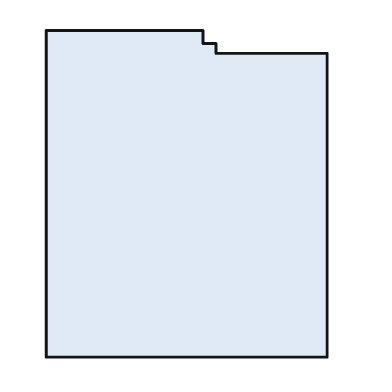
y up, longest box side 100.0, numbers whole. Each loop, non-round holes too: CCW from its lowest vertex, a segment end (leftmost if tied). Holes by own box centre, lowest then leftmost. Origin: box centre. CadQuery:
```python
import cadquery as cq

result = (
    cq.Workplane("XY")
    .moveTo(-43.0, -50.0)
    .lineTo(43.0, -50.0)
    .lineTo(43.0, 43.0)
    .lineTo(9.0, 43.0)
    .lineTo(9.0, 46.0)
    .lineTo(5.0, 46.0)
    .lineTo(5.0, 50.0)
    .lineTo(-43.0, 50.0)
    .close()
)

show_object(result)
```